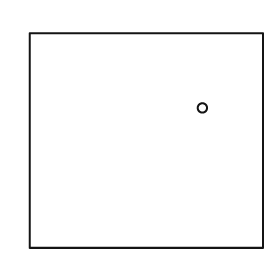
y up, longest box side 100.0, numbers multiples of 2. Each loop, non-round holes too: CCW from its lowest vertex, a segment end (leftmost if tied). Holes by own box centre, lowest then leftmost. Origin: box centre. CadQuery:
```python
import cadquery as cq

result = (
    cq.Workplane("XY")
    .moveTo(-50.0, -46.0)
    .lineTo(50.0, -46.0)
    .lineTo(50.0, 46.0)
    .lineTo(-50.0, 46.0)
    .close()
    .moveTo(24.0, 14.0)
    .circle(2.0)
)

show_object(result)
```